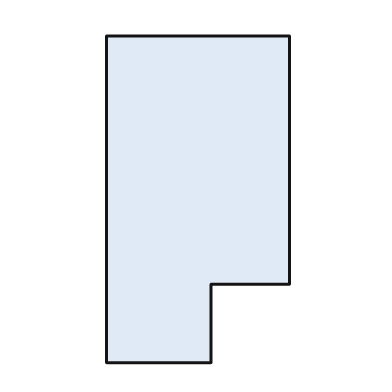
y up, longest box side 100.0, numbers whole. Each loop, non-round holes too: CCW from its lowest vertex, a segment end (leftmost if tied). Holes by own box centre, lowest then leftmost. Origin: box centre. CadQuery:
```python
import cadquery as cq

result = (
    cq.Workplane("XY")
    .moveTo(-28.0, -50.0)
    .lineTo(4.0, -50.0)
    .lineTo(4.0, -26.0)
    .lineTo(28.0, -26.0)
    .lineTo(28.0, 50.0)
    .lineTo(-28.0, 50.0)
    .close()
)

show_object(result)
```